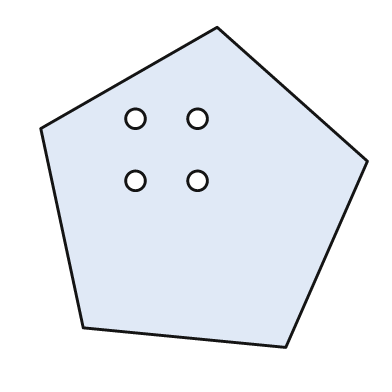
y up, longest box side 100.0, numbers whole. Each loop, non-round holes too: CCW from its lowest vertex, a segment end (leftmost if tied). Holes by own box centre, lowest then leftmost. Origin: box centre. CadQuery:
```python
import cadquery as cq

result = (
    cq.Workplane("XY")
    .moveTo(25.0, -49.0)
    .lineTo(50.0, 8.0)
    .lineTo(4.0, 49.0)
    .lineTo(-50.0, 18.0)
    .lineTo(-37.0, -43.0)
    .close()
    .moveTo(-21.0, 2.0)
    .circle(3.0)
    .moveTo(-2.0, 2.0)
    .circle(3.0)
    .moveTo(-21.0, 21.0)
    .circle(3.0)
    .moveTo(-2.0, 21.0)
    .circle(3.0)
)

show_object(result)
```